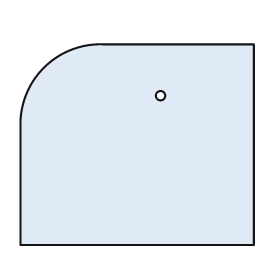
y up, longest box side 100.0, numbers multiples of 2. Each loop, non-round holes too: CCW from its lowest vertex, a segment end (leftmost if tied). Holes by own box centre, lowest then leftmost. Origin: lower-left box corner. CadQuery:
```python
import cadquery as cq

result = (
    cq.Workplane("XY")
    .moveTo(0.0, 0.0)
    .lineTo(100.0, 0.0)
    .lineTo(100.0, 86.0)
    .lineTo(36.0, 86.0)
    .threePointArc((10.0, 76.0), (0.0, 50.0))
    .close()
    .moveTo(60.0, 64.0)
    .circle(2.0)
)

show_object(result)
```